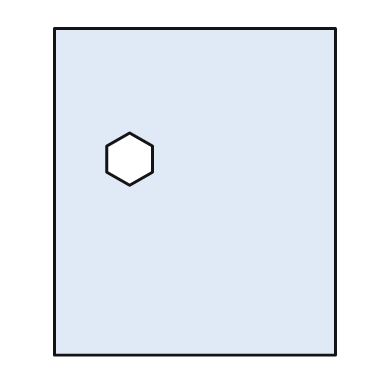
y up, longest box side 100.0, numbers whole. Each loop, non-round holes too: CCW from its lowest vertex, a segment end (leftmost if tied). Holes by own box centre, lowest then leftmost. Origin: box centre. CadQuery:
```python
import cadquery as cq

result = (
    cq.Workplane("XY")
    .moveTo(-43.0, -50.0)
    .lineTo(43.0, -50.0)
    .lineTo(43.0, 50.0)
    .lineTo(-43.0, 50.0)
    .close()
    .moveTo(-20.0, 2.0)
    .lineTo(-13.0, 6.0)
    .lineTo(-13.0, 14.0)
    .lineTo(-20.0, 18.0)
    .lineTo(-27.0, 14.0)
    .lineTo(-27.0, 6.0)
    .close()
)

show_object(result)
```